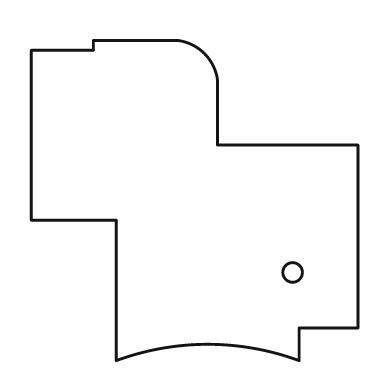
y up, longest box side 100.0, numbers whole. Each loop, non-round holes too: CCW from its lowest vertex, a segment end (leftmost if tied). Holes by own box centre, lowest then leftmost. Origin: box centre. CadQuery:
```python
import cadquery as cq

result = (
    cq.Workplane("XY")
    .moveTo(-24.0, -49.0)
    .threePointArc((4.0, -44.0), (32.0, -49.0))
    .lineTo(32.0, -39.0)
    .lineTo(50.0, -39.0)
    .lineTo(50.0, 17.0)
    .lineTo(7.0, 17.0)
    .lineTo(7.0, 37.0)
    .threePointArc((3.0, 45.0), (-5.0, 49.0))
    .lineTo(-31.0, 49.0)
    .lineTo(-31.0, 46.0)
    .lineTo(-50.0, 46.0)
    .lineTo(-50.0, -6.0)
    .lineTo(-24.0, -6.0)
    .close()
    .moveTo(30.0, -22.0)
    .circle(3.0)
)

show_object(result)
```